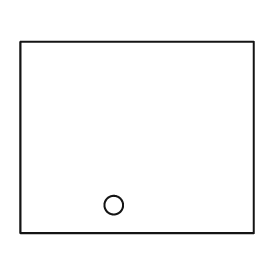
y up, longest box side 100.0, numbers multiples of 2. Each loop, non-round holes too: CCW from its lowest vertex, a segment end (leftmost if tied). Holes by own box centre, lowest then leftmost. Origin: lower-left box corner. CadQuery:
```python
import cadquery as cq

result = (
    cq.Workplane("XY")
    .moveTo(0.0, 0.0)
    .lineTo(100.0, 0.0)
    .lineTo(100.0, 82.0)
    .lineTo(0.0, 82.0)
    .close()
    .moveTo(40.0, 12.0)
    .circle(4.0)
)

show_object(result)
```